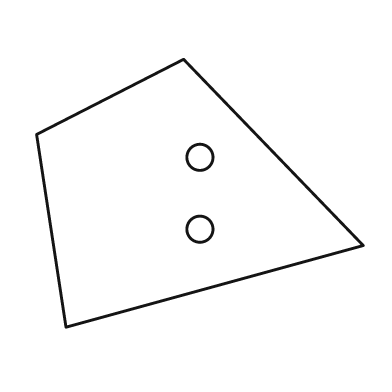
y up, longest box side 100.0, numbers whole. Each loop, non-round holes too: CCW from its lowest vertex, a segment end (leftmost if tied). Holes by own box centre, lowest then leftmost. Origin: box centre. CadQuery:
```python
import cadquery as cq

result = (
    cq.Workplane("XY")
    .moveTo(-41.0, -41.0)
    .lineTo(50.0, -16.0)
    .lineTo(-5.0, 41.0)
    .lineTo(-50.0, 18.0)
    .close()
    .moveTo(0.0, -11.0)
    .circle(4.0)
    .moveTo(0.0, 11.0)
    .circle(4.0)
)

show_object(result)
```